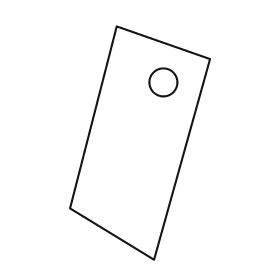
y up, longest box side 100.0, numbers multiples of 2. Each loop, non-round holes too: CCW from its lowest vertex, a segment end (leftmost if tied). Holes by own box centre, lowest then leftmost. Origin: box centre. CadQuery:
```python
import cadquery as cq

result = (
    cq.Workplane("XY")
    .moveTo(6.0, -50.0)
    .lineTo(30.0, 36.0)
    .lineTo(-10.0, 50.0)
    .lineTo(-30.0, -28.0)
    .close()
    .moveTo(10.0, 26.0)
    .circle(6.0)
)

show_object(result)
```